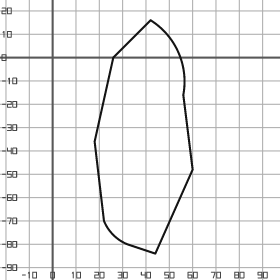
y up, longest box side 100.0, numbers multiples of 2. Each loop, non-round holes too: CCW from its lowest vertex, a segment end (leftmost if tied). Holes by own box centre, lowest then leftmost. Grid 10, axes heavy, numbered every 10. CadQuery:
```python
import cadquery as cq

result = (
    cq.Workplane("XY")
    .moveTo(44.0, -84.0)
    .lineTo(60.0, -48.0)
    .lineTo(56.0, -16.0)
    .threePointArc((54.0, 2.0), (42.0, 16.0))
    .lineTo(26.0, 0.0)
    .lineTo(18.0, -36.0)
    .lineTo(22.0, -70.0)
    .threePointArc((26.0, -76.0), (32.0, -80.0))
    .close()
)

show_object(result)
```